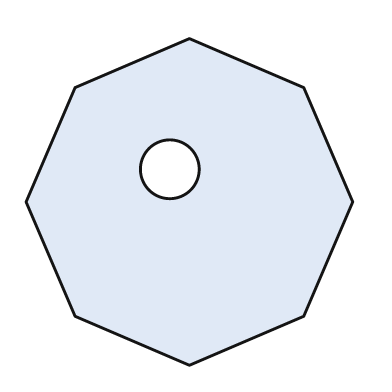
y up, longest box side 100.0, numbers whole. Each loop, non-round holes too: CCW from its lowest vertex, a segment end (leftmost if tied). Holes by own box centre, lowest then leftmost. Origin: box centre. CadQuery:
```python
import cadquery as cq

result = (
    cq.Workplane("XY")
    .moveTo(0.0, -50.0)
    .lineTo(35.0, -35.0)
    .lineTo(50.0, 0.0)
    .lineTo(35.0, 35.0)
    .lineTo(0.0, 50.0)
    .lineTo(-35.0, 35.0)
    .lineTo(-50.0, 0.0)
    .lineTo(-35.0, -35.0)
    .close()
    .moveTo(-6.0, 10.0)
    .circle(9.0)
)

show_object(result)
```